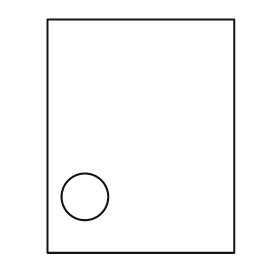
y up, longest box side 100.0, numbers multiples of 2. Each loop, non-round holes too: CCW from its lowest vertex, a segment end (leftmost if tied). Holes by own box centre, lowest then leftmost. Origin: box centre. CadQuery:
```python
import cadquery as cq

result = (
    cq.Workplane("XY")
    .moveTo(-40.0, -50.0)
    .lineTo(40.0, -50.0)
    .lineTo(40.0, 50.0)
    .lineTo(-40.0, 50.0)
    .close()
    .moveTo(-24.0, -26.0)
    .circle(10.0)
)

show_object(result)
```